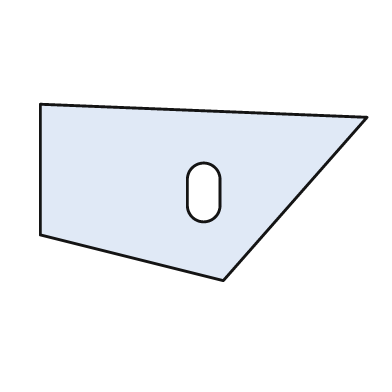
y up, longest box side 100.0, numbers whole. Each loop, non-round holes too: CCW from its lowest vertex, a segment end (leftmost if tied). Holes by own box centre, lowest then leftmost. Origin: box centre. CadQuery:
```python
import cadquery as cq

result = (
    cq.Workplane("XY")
    .moveTo(6.0, -27.0)
    .lineTo(50.0, 23.0)
    .lineTo(-50.0, 27.0)
    .lineTo(-50.0, -13.0)
    .close()
    .moveTo(-5.0, -4.0)
    .threePointArc((0.0, -9.0), (5.0, -4.0))
    .lineTo(5.0, 4.0)
    .threePointArc((0.0, 9.0), (-5.0, 4.0))
    .close()
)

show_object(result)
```